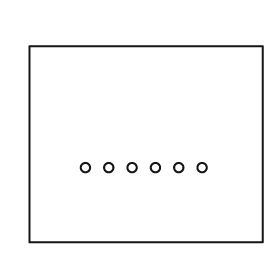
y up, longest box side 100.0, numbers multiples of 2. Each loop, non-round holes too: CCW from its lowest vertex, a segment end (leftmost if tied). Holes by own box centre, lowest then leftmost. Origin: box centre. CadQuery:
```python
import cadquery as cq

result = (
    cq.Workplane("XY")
    .moveTo(-50.0, -42.0)
    .lineTo(50.0, -42.0)
    .lineTo(50.0, 42.0)
    .lineTo(-50.0, 42.0)
    .close()
    .moveTo(-26.0, -10.0)
    .circle(2.0)
    .moveTo(-16.0, -10.0)
    .circle(2.0)
    .moveTo(-6.0, -10.0)
    .circle(2.0)
    .moveTo(4.0, -10.0)
    .circle(2.0)
    .moveTo(14.0, -10.0)
    .circle(2.0)
    .moveTo(24.0, -10.0)
    .circle(2.0)
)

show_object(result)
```